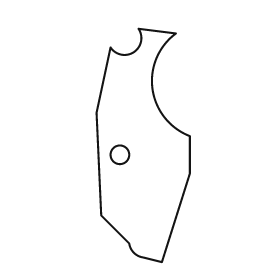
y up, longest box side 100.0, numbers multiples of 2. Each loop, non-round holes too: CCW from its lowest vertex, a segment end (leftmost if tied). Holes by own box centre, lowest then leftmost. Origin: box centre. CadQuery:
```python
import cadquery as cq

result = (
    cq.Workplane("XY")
    .moveTo(8.0, -50.0)
    .lineTo(20.0, -12.0)
    .lineTo(20.0, 4.0)
    .threePointArc((4.0, 24.0), (14.0, 48.0))
    .lineTo(-2.0, 50.0)
    .threePointArc((-4.0, 40.0), (-14.0, 42.0))
    .lineTo(-20.0, 14.0)
    .lineTo(-18.0, -30.0)
    .lineTo(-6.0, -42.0)
    .threePointArc((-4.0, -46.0), (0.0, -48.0))
    .close()
    .moveTo(-10.0, -4.0)
    .circle(4.0)
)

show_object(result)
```